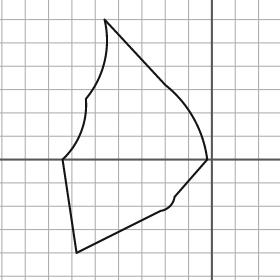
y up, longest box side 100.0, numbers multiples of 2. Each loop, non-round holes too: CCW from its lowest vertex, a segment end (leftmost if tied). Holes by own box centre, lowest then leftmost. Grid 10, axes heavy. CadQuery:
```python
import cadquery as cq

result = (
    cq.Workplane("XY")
    .moveTo(-58.0, -40.0)
    .lineTo(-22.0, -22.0)
    .threePointArc((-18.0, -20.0), (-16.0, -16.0))
    .lineTo(-2.0, 0.0)
    .threePointArc((-8.0, 18.0), (-20.0, 32.0))
    .lineTo(-46.0, 60.0)
    .threePointArc((-46.0, 42.0), (-54.0, 26.0))
    .threePointArc((-56.0, 12.0), (-64.0, 0.0))
    .close()
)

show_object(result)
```